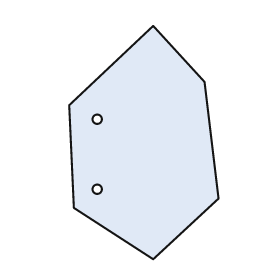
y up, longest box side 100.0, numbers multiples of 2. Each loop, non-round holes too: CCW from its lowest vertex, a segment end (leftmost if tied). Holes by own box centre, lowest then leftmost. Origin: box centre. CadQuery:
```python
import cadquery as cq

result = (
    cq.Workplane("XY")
    .moveTo(4.0, -50.0)
    .lineTo(32.0, -24.0)
    .lineTo(26.0, 26.0)
    .lineTo(4.0, 50.0)
    .lineTo(-32.0, 16.0)
    .lineTo(-30.0, -28.0)
    .close()
    .moveTo(-20.0, -20.0)
    .circle(2.0)
    .moveTo(-20.0, 10.0)
    .circle(2.0)
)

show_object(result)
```